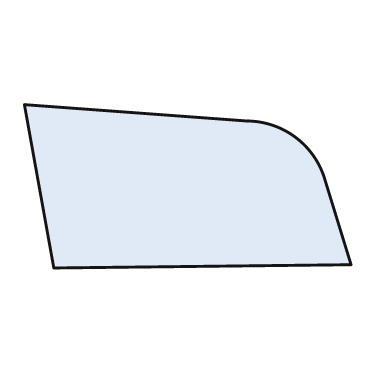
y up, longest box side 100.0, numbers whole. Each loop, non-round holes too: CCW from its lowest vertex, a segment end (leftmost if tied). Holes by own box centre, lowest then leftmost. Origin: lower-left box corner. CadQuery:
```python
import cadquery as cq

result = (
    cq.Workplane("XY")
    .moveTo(9.0, 0.0)
    .lineTo(100.0, 1.0)
    .lineTo(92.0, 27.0)
    .threePointArc((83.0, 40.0), (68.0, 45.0))
    .lineTo(0.0, 50.0)
    .close()
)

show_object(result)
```